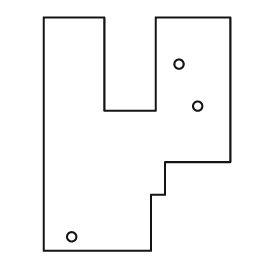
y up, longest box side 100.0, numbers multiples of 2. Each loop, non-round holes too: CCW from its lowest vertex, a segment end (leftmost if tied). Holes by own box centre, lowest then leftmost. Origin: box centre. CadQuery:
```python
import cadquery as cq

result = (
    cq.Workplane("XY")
    .moveTo(-40.0, -50.0)
    .lineTo(6.0, -50.0)
    .lineTo(6.0, -26.0)
    .lineTo(12.0, -26.0)
    .lineTo(12.0, -12.0)
    .lineTo(40.0, -12.0)
    .lineTo(40.0, 50.0)
    .lineTo(8.0, 50.0)
    .lineTo(8.0, 10.0)
    .lineTo(-14.0, 10.0)
    .lineTo(-14.0, 50.0)
    .lineTo(-40.0, 50.0)
    .close()
    .moveTo(-28.0, -44.0)
    .circle(2.0)
    .moveTo(26.0, 12.0)
    .circle(2.0)
    .moveTo(18.0, 30.0)
    .circle(2.0)
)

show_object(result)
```